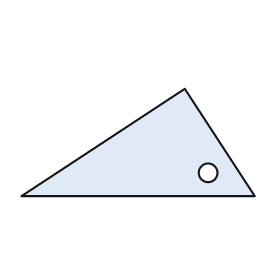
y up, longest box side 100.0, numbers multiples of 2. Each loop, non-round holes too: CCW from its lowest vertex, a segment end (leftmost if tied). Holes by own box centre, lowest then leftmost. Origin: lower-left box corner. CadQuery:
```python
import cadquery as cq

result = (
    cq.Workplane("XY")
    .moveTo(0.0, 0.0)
    .lineTo(100.0, 0.0)
    .lineTo(70.0, 46.0)
    .close()
    .moveTo(80.0, 10.0)
    .circle(4.0)
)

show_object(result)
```